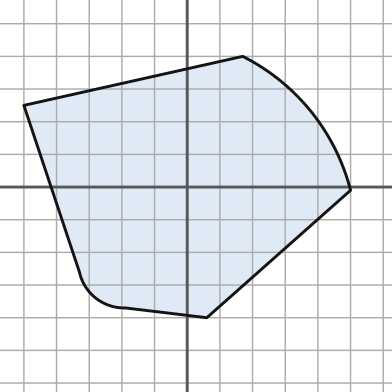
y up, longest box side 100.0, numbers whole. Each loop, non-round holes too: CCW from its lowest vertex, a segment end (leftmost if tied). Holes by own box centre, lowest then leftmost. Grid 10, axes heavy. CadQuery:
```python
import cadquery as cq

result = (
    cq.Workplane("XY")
    .moveTo(6.0, -40.0)
    .lineTo(50.0, -1.0)
    .threePointArc((38.0, 23.0), (17.0, 40.0))
    .lineTo(-50.0, 25.0)
    .lineTo(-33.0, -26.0)
    .threePointArc((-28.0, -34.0), (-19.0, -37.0))
    .close()
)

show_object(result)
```